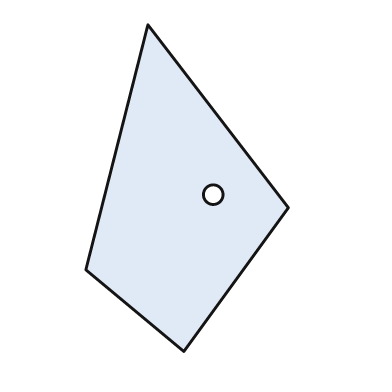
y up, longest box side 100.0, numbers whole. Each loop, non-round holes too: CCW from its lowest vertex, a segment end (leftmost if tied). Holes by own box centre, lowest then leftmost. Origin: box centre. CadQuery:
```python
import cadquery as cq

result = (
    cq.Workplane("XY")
    .moveTo(-1.0, -50.0)
    .lineTo(31.0, -6.0)
    .lineTo(-12.0, 50.0)
    .lineTo(-31.0, -25.0)
    .close()
    .moveTo(8.0, -2.0)
    .circle(3.0)
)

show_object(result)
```